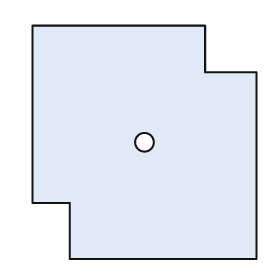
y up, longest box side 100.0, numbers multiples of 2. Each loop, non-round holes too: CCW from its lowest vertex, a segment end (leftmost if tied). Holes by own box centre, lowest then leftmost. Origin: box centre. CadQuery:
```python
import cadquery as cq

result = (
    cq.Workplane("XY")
    .moveTo(-32.0, -50.0)
    .lineTo(48.0, -50.0)
    .lineTo(48.0, 30.0)
    .lineTo(26.0, 30.0)
    .lineTo(26.0, 50.0)
    .lineTo(-48.0, 50.0)
    .lineTo(-48.0, -26.0)
    .lineTo(-32.0, -26.0)
    .close()
    .moveTo(0.0, 0.0)
    .circle(4.0)
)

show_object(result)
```